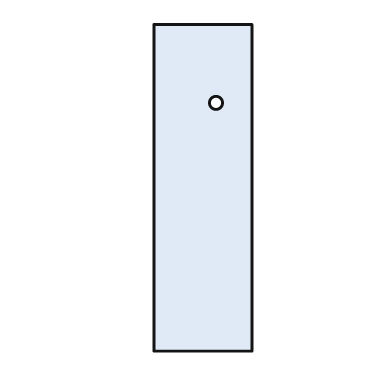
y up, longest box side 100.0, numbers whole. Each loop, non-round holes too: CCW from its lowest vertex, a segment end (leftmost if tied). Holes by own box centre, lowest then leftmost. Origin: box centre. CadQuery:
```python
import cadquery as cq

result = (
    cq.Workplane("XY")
    .moveTo(-15.0, -50.0)
    .lineTo(15.0, -50.0)
    .lineTo(15.0, 50.0)
    .lineTo(-15.0, 50.0)
    .close()
    .moveTo(4.0, 26.0)
    .circle(2.0)
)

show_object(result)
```